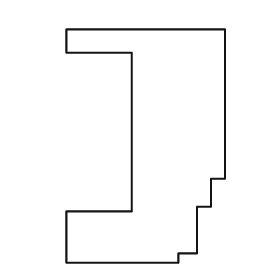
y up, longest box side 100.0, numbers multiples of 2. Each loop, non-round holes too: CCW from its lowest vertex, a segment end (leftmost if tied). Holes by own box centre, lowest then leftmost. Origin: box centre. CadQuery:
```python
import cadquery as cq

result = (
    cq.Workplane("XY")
    .moveTo(-34.0, -50.0)
    .lineTo(14.0, -50.0)
    .lineTo(14.0, -46.0)
    .lineTo(22.0, -46.0)
    .lineTo(22.0, -26.0)
    .lineTo(28.0, -26.0)
    .lineTo(28.0, -14.0)
    .lineTo(34.0, -14.0)
    .lineTo(34.0, 50.0)
    .lineTo(-34.0, 50.0)
    .lineTo(-34.0, 40.0)
    .lineTo(-6.0, 40.0)
    .lineTo(-6.0, -28.0)
    .lineTo(-34.0, -28.0)
    .close()
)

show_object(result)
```